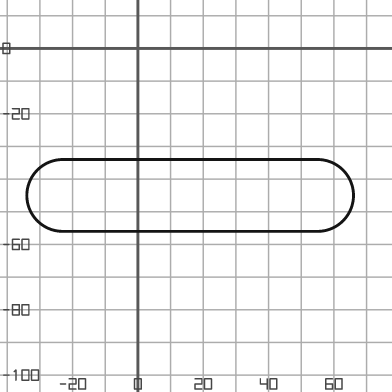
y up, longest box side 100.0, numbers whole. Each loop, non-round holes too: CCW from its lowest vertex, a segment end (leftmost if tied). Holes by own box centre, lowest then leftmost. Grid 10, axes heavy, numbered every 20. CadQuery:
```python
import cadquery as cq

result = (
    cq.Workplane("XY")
    .moveTo(-23.0, -56.0)
    .lineTo(55.0, -56.0)
    .threePointArc((66.0, -45.0), (55.0, -34.0))
    .lineTo(-23.0, -34.0)
    .threePointArc((-34.0, -45.0), (-23.0, -56.0))
    .close()
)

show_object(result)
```